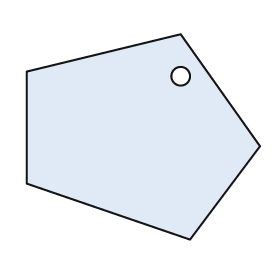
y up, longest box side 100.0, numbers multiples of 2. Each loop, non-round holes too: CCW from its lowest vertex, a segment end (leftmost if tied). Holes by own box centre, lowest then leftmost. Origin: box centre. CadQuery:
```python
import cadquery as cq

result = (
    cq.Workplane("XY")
    .moveTo(20.0, -44.0)
    .lineTo(50.0, -4.0)
    .lineTo(16.0, 44.0)
    .lineTo(-50.0, 28.0)
    .lineTo(-50.0, -20.0)
    .close()
    .moveTo(16.0, 26.0)
    .circle(4.0)
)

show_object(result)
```